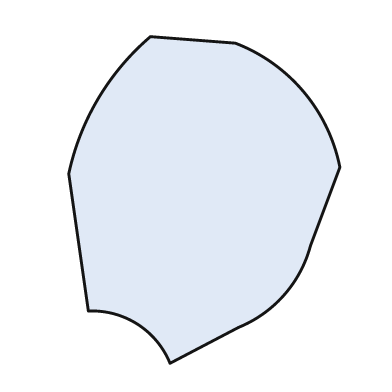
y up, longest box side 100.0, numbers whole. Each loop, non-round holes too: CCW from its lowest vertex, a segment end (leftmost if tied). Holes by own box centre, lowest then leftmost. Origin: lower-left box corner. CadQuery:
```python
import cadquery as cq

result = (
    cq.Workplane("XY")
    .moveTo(31.0, 0.0)
    .lineTo(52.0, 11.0)
    .threePointArc((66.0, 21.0), (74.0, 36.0))
    .lineTo(83.0, 60.0)
    .threePointArc((72.0, 83.0), (51.0, 98.0))
    .lineTo(25.0, 100.0)
    .threePointArc((9.0, 81.0), (0.0, 58.0))
    .lineTo(6.0, 16.0)
    .threePointArc((21.0, 12.0), (31.0, 0.0))
    .close()
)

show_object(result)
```